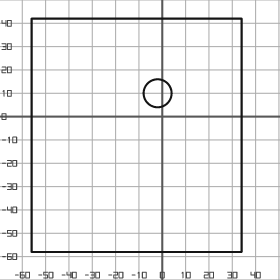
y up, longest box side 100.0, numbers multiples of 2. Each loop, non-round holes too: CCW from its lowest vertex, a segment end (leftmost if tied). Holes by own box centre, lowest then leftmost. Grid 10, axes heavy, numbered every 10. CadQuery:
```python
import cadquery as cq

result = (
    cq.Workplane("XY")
    .moveTo(-56.0, -58.0)
    .lineTo(34.0, -58.0)
    .lineTo(34.0, 42.0)
    .lineTo(-56.0, 42.0)
    .close()
    .moveTo(-2.0, 10.0)
    .circle(6.0)
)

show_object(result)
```